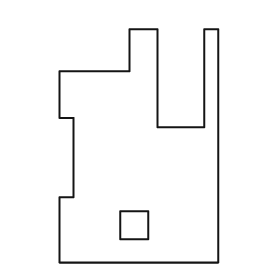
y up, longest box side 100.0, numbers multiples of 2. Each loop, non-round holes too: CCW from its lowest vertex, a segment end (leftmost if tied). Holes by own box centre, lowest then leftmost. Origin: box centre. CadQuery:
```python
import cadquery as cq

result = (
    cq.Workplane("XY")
    .moveTo(-34.0, -50.0)
    .lineTo(34.0, -50.0)
    .lineTo(34.0, 50.0)
    .lineTo(28.0, 50.0)
    .lineTo(28.0, 8.0)
    .lineTo(8.0, 8.0)
    .lineTo(8.0, 50.0)
    .lineTo(-4.0, 50.0)
    .lineTo(-4.0, 32.0)
    .lineTo(-34.0, 32.0)
    .lineTo(-34.0, 12.0)
    .lineTo(-28.0, 12.0)
    .lineTo(-28.0, -22.0)
    .lineTo(-34.0, -22.0)
    .close()
    .moveTo(-8.0, -40.0)
    .lineTo(4.0, -40.0)
    .lineTo(4.0, -28.0)
    .lineTo(-8.0, -28.0)
    .close()
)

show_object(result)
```